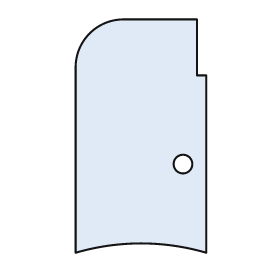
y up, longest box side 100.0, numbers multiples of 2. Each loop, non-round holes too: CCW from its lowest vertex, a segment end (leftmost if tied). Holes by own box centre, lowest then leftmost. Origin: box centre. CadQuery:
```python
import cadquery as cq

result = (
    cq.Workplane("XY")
    .moveTo(-28.0, -50.0)
    .threePointArc((0.0, -46.0), (28.0, -50.0))
    .lineTo(28.0, 26.0)
    .lineTo(24.0, 26.0)
    .lineTo(24.0, 50.0)
    .lineTo(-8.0, 50.0)
    .threePointArc((-22.0, 44.0), (-28.0, 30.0))
    .close()
    .moveTo(18.0, -12.0)
    .circle(4.0)
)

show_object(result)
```